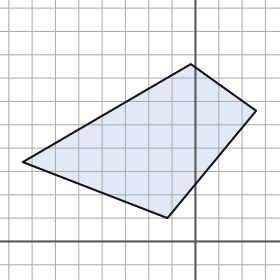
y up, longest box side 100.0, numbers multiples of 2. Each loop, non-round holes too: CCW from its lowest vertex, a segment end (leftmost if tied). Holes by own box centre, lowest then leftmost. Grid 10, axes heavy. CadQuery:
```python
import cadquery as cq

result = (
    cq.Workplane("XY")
    .moveTo(-12.0, 10.0)
    .lineTo(26.0, 56.0)
    .lineTo(-2.0, 76.0)
    .lineTo(-74.0, 34.0)
    .close()
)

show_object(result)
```